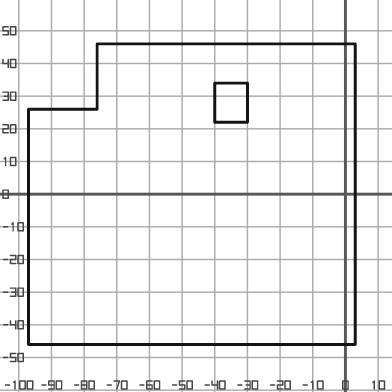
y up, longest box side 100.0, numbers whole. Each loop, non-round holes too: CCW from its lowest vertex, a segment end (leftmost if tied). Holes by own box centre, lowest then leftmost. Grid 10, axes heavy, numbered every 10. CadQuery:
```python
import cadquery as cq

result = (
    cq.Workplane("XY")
    .moveTo(-97.0, -46.0)
    .lineTo(3.0, -46.0)
    .lineTo(3.0, 46.0)
    .lineTo(-76.0, 46.0)
    .lineTo(-76.0, 26.0)
    .lineTo(-97.0, 26.0)
    .close()
    .moveTo(-40.0, 22.0)
    .lineTo(-30.0, 22.0)
    .lineTo(-30.0, 34.0)
    .lineTo(-40.0, 34.0)
    .close()
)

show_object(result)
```